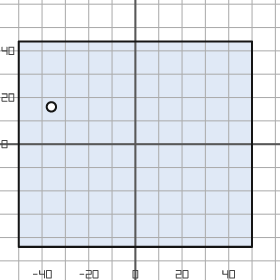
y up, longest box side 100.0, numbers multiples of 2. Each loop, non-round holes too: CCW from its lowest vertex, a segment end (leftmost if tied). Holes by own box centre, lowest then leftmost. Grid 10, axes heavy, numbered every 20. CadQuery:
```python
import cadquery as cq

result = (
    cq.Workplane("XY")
    .moveTo(-50.0, -44.0)
    .lineTo(50.0, -44.0)
    .lineTo(50.0, 44.0)
    .lineTo(-50.0, 44.0)
    .close()
    .moveTo(-36.0, 16.0)
    .circle(2.0)
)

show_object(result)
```